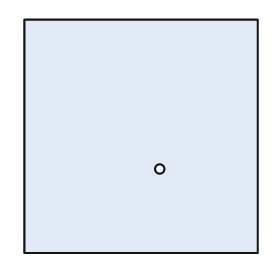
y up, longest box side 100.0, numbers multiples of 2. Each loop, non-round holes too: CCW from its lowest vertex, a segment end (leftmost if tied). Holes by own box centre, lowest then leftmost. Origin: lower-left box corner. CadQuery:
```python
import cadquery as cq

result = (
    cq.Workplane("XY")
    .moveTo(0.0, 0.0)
    .lineTo(100.0, 0.0)
    .lineTo(100.0, 100.0)
    .lineTo(0.0, 100.0)
    .close()
    .moveTo(58.0, 36.0)
    .circle(2.0)
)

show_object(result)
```